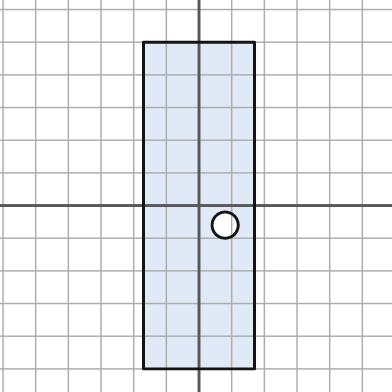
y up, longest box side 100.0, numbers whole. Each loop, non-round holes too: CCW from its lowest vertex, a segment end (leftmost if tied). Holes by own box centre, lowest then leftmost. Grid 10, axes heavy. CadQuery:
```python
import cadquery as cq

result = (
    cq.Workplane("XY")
    .moveTo(-17.0, -50.0)
    .lineTo(17.0, -50.0)
    .lineTo(17.0, 50.0)
    .lineTo(-17.0, 50.0)
    .close()
    .moveTo(8.0, -6.0)
    .circle(4.0)
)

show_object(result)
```